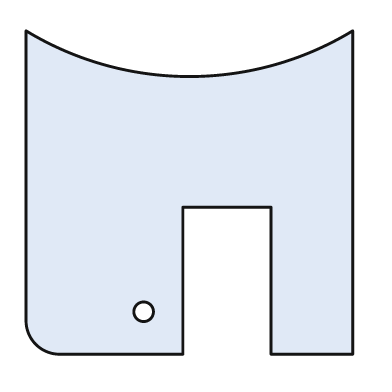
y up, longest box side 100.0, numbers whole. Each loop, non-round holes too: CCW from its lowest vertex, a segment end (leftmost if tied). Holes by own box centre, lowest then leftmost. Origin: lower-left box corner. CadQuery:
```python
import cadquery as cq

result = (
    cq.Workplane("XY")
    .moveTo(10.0, 0.0)
    .lineTo(48.0, 0.0)
    .lineTo(48.0, 45.0)
    .lineTo(75.0, 45.0)
    .lineTo(75.0, 0.0)
    .lineTo(100.0, 0.0)
    .lineTo(100.0, 99.0)
    .threePointArc((50.0, 85.0), (0.0, 99.0))
    .lineTo(0.0, 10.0)
    .threePointArc((3.0, 3.0), (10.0, 0.0))
    .close()
    .moveTo(36.0, 13.0)
    .circle(3.0)
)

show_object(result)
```